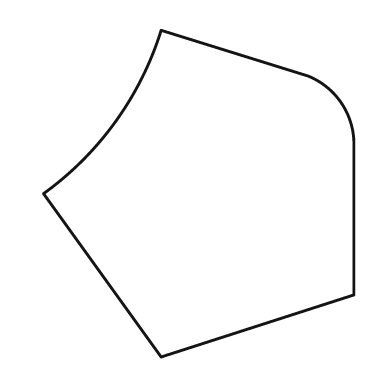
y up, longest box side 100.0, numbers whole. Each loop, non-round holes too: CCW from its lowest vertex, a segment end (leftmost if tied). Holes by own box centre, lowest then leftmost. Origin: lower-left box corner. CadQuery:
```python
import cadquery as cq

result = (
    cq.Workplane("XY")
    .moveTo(36.0, 0.0)
    .lineTo(95.0, 19.0)
    .lineTo(95.0, 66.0)
    .threePointArc((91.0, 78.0), (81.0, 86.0))
    .lineTo(36.0, 100.0)
    .threePointArc((22.0, 72.0), (0.0, 50.0))
    .close()
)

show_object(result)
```